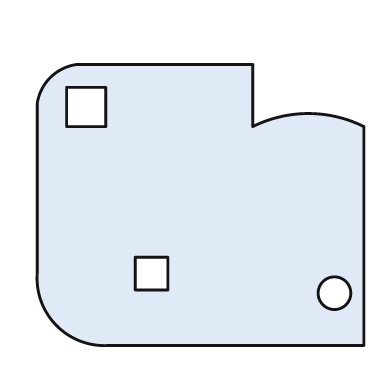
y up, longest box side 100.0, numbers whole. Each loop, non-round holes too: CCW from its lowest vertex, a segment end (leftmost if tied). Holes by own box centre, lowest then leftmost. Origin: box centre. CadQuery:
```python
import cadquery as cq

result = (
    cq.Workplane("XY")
    .moveTo(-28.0, -43.0)
    .lineTo(50.0, -43.0)
    .lineTo(50.0, 24.0)
    .threePointArc((33.0, 28.0), (16.0, 24.0))
    .lineTo(16.0, 43.0)
    .lineTo(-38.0, 43.0)
    .threePointArc((-46.0, 39.0), (-50.0, 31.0))
    .lineTo(-50.0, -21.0)
    .threePointArc((-44.0, -37.0), (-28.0, -43.0))
    .close()
    .moveTo(41.0, -27.0)
    .circle(5.0)
    .moveTo(-20.0, -26.0)
    .lineTo(-10.0, -26.0)
    .lineTo(-10.0, -16.0)
    .lineTo(-20.0, -16.0)
    .close()
    .moveTo(-41.0, 24.0)
    .lineTo(-29.0, 24.0)
    .lineTo(-29.0, 36.0)
    .lineTo(-41.0, 36.0)
    .close()
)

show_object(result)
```